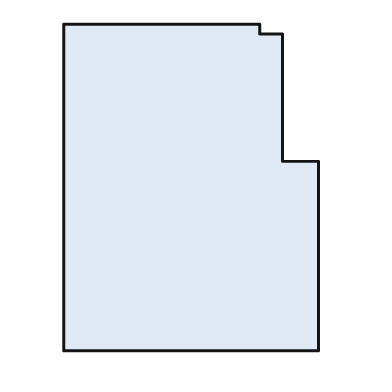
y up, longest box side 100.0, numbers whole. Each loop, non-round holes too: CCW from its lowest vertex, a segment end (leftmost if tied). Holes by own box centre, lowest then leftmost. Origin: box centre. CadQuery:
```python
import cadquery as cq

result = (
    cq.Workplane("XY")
    .moveTo(-39.0, -50.0)
    .lineTo(39.0, -50.0)
    .lineTo(39.0, 8.0)
    .lineTo(28.0, 8.0)
    .lineTo(28.0, 47.0)
    .lineTo(21.0, 47.0)
    .lineTo(21.0, 50.0)
    .lineTo(-39.0, 50.0)
    .close()
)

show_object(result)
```